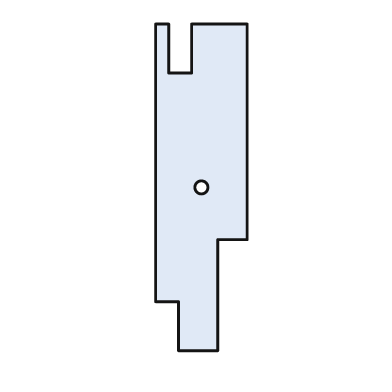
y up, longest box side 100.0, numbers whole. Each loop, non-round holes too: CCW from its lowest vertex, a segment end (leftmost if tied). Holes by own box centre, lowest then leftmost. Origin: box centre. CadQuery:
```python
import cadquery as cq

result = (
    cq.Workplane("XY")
    .moveTo(-7.0, -50.0)
    .lineTo(5.0, -50.0)
    .lineTo(5.0, -16.0)
    .lineTo(14.0, -16.0)
    .lineTo(14.0, 50.0)
    .lineTo(-3.0, 50.0)
    .lineTo(-3.0, 35.0)
    .lineTo(-10.0, 35.0)
    .lineTo(-10.0, 50.0)
    .lineTo(-14.0, 50.0)
    .lineTo(-14.0, -35.0)
    .lineTo(-7.0, -35.0)
    .close()
    .moveTo(0.0, 0.0)
    .circle(2.0)
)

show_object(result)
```